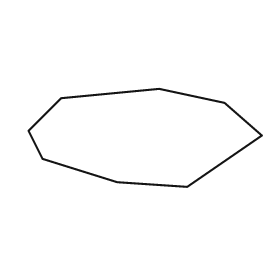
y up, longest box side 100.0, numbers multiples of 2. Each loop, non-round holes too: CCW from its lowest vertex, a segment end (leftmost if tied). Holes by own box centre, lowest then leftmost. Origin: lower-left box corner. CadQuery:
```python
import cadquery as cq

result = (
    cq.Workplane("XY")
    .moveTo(68.0, 0.0)
    .lineTo(100.0, 22.0)
    .lineTo(84.0, 36.0)
    .lineTo(56.0, 42.0)
    .lineTo(14.0, 38.0)
    .lineTo(0.0, 24.0)
    .lineTo(6.0, 12.0)
    .lineTo(38.0, 2.0)
    .close()
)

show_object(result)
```